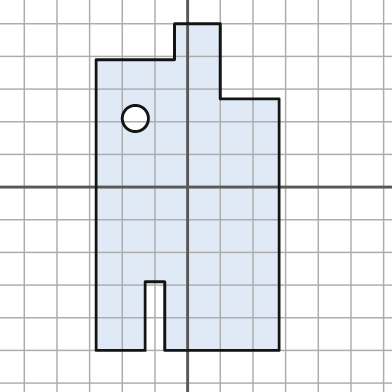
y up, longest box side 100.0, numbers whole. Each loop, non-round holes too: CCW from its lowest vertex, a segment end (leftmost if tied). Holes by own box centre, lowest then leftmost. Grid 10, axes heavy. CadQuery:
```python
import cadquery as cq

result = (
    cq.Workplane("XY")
    .moveTo(-28.0, -50.0)
    .lineTo(-13.0, -50.0)
    .lineTo(-13.0, -29.0)
    .lineTo(-7.0, -29.0)
    .lineTo(-7.0, -50.0)
    .lineTo(28.0, -50.0)
    .lineTo(28.0, 27.0)
    .lineTo(10.0, 27.0)
    .lineTo(10.0, 50.0)
    .lineTo(-4.0, 50.0)
    .lineTo(-4.0, 39.0)
    .lineTo(-28.0, 39.0)
    .close()
    .moveTo(-16.0, 21.0)
    .circle(4.0)
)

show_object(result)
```